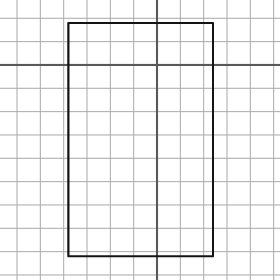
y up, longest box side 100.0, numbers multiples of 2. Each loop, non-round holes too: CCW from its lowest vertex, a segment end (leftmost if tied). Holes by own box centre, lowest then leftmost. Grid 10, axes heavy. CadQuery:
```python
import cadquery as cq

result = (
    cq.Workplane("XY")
    .moveTo(-38.0, -82.0)
    .lineTo(24.0, -82.0)
    .lineTo(24.0, 18.0)
    .lineTo(-38.0, 18.0)
    .close()
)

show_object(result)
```